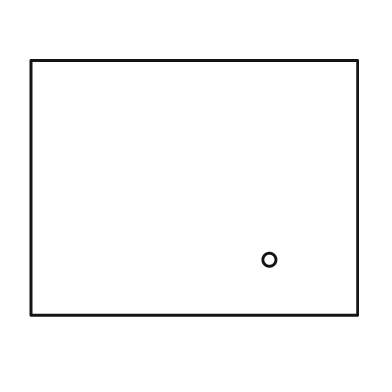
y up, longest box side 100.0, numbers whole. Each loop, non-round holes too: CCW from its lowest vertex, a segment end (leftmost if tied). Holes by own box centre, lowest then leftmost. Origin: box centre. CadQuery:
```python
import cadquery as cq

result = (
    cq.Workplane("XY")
    .moveTo(-50.0, -39.0)
    .lineTo(50.0, -39.0)
    .lineTo(50.0, 39.0)
    .lineTo(-50.0, 39.0)
    .close()
    .moveTo(23.0, -22.0)
    .circle(2.0)
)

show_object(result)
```